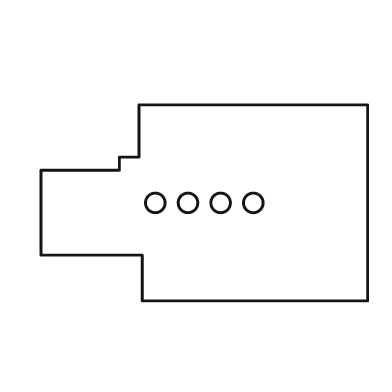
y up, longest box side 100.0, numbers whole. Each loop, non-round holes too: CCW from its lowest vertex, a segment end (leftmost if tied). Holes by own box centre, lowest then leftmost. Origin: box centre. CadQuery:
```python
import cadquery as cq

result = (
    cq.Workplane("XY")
    .moveTo(-19.0, -30.0)
    .lineTo(50.0, -30.0)
    .lineTo(50.0, 30.0)
    .lineTo(-20.0, 30.0)
    .lineTo(-20.0, 14.0)
    .lineTo(-26.0, 14.0)
    .lineTo(-26.0, 10.0)
    .lineTo(-50.0, 10.0)
    .lineTo(-50.0, -16.0)
    .lineTo(-19.0, -16.0)
    .close()
    .moveTo(-15.0, 0.0)
    .circle(3.0)
    .moveTo(-5.0, 0.0)
    .circle(3.0)
    .moveTo(5.0, 0.0)
    .circle(3.0)
    .moveTo(15.0, 0.0)
    .circle(3.0)
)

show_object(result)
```